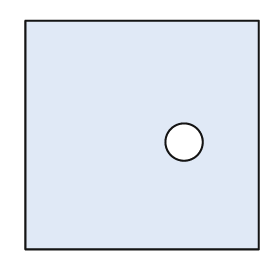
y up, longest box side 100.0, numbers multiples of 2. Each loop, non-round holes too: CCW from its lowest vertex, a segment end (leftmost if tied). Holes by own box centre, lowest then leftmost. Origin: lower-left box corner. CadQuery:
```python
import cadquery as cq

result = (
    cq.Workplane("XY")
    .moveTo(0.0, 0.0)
    .lineTo(100.0, 0.0)
    .lineTo(100.0, 98.0)
    .lineTo(0.0, 98.0)
    .close()
    .moveTo(68.0, 46.0)
    .circle(8.0)
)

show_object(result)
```